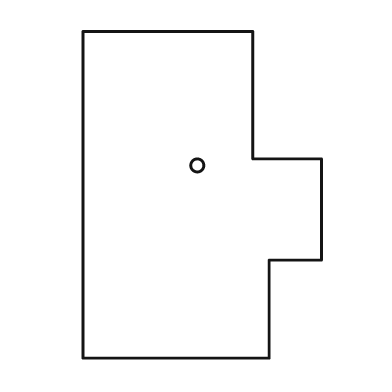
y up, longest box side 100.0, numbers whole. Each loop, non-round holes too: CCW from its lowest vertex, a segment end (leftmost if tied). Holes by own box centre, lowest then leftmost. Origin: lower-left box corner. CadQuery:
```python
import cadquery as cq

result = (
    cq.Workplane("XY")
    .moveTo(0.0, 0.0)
    .lineTo(57.0, 0.0)
    .lineTo(57.0, 30.0)
    .lineTo(73.0, 30.0)
    .lineTo(73.0, 61.0)
    .lineTo(52.0, 61.0)
    .lineTo(52.0, 100.0)
    .lineTo(0.0, 100.0)
    .close()
    .moveTo(35.0, 59.0)
    .circle(2.0)
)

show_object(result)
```